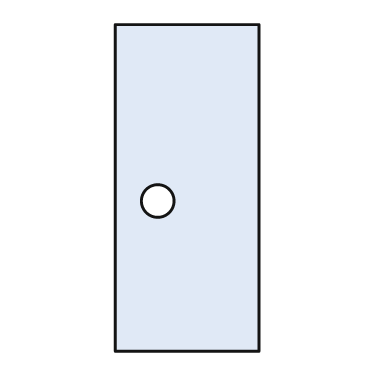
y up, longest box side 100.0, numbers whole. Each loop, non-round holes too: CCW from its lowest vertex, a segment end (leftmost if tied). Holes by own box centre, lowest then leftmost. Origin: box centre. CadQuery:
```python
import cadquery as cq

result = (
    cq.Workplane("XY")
    .moveTo(-22.0, -50.0)
    .lineTo(22.0, -50.0)
    .lineTo(22.0, 50.0)
    .lineTo(-22.0, 50.0)
    .close()
    .moveTo(-9.0, -4.0)
    .circle(5.0)
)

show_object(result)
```